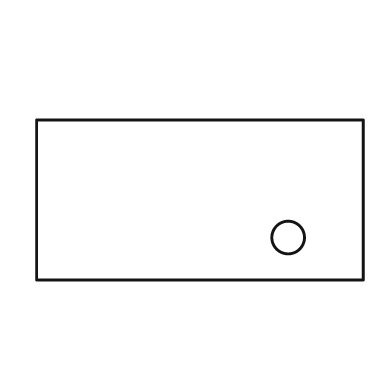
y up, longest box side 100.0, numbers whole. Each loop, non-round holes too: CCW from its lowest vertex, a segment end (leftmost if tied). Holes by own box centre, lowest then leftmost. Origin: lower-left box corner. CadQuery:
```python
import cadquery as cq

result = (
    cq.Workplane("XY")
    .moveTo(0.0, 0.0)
    .lineTo(100.0, 0.0)
    .lineTo(100.0, 49.0)
    .lineTo(0.0, 49.0)
    .close()
    .moveTo(77.0, 13.0)
    .circle(5.0)
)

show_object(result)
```